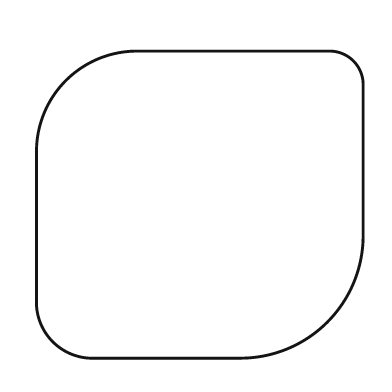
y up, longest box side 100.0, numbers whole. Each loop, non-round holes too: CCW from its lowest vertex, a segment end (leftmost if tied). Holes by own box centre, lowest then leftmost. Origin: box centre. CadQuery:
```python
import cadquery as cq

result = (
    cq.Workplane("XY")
    .moveTo(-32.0, -47.0)
    .lineTo(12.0, -47.0)
    .threePointArc((39.0, -36.0), (50.0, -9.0))
    .lineTo(50.0, 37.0)
    .threePointArc((47.0, 44.0), (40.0, 47.0))
    .lineTo(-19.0, 47.0)
    .threePointArc((-41.0, 38.0), (-50.0, 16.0))
    .lineTo(-50.0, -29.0)
    .threePointArc((-45.0, -42.0), (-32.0, -47.0))
    .close()
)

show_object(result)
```